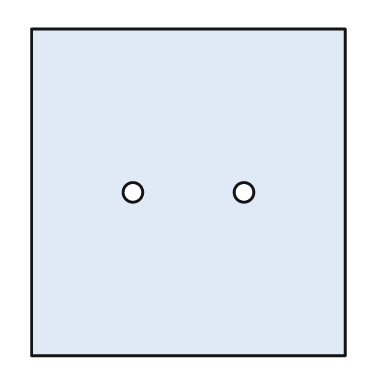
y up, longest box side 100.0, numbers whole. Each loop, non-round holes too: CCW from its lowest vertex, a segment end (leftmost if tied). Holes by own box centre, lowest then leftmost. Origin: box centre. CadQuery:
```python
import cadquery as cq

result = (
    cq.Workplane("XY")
    .moveTo(-48.0, -50.0)
    .lineTo(48.0, -50.0)
    .lineTo(48.0, 50.0)
    .lineTo(-48.0, 50.0)
    .close()
    .moveTo(-17.0, 0.0)
    .circle(3.0)
    .moveTo(17.0, 0.0)
    .circle(3.0)
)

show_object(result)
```